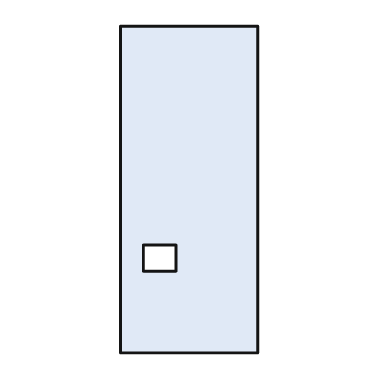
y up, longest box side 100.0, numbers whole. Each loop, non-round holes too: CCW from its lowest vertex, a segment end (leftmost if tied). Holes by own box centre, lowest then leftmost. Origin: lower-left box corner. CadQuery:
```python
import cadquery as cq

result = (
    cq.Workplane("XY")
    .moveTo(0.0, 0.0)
    .lineTo(42.0, 0.0)
    .lineTo(42.0, 100.0)
    .lineTo(0.0, 100.0)
    .close()
    .moveTo(7.0, 25.0)
    .lineTo(17.0, 25.0)
    .lineTo(17.0, 33.0)
    .lineTo(7.0, 33.0)
    .close()
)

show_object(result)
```